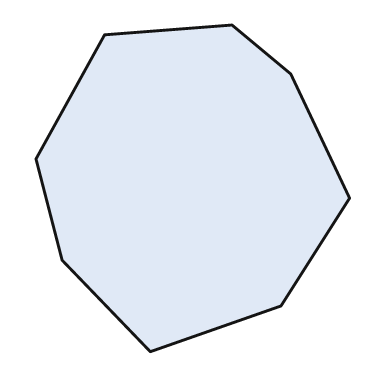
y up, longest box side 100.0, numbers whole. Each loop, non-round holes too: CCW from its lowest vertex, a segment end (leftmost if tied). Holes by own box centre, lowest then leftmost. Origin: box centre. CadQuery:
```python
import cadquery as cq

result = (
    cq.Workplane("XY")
    .moveTo(-13.0, -50.0)
    .lineTo(27.0, -36.0)
    .lineTo(48.0, -3.0)
    .lineTo(30.0, 35.0)
    .lineTo(12.0, 50.0)
    .lineTo(-27.0, 47.0)
    .lineTo(-48.0, 9.0)
    .lineTo(-40.0, -22.0)
    .close()
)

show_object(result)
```